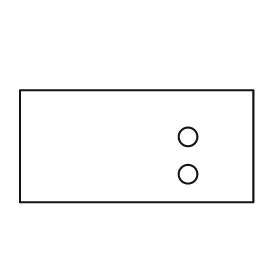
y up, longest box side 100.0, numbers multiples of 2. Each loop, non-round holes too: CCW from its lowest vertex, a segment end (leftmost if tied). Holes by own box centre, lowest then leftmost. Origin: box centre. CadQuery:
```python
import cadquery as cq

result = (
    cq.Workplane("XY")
    .moveTo(-50.0, -24.0)
    .lineTo(50.0, -24.0)
    .lineTo(50.0, 24.0)
    .lineTo(-50.0, 24.0)
    .close()
    .moveTo(22.0, -12.0)
    .circle(4.0)
    .moveTo(22.0, 4.0)
    .circle(4.0)
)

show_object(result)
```